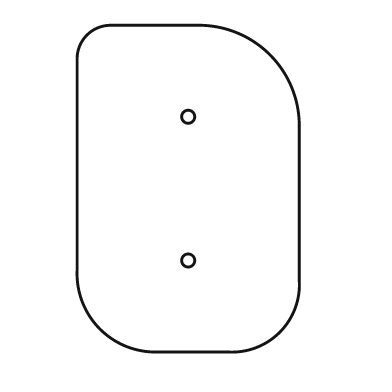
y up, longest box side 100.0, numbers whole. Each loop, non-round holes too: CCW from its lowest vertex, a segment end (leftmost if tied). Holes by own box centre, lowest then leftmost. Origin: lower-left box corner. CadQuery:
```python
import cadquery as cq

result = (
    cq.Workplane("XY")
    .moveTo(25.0, 0.0)
    .lineTo(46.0, 0.0)
    .threePointArc((62.0, 6.0), (68.0, 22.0))
    .lineTo(68.0, 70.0)
    .threePointArc((59.0, 91.0), (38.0, 100.0))
    .lineTo(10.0, 100.0)
    .threePointArc((3.0, 97.0), (0.0, 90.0))
    .lineTo(0.0, 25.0)
    .threePointArc((7.0, 7.0), (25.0, 0.0))
    .close()
    .moveTo(34.0, 28.0)
    .circle(2.0)
    .moveTo(34.0, 72.0)
    .circle(2.0)
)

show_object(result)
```